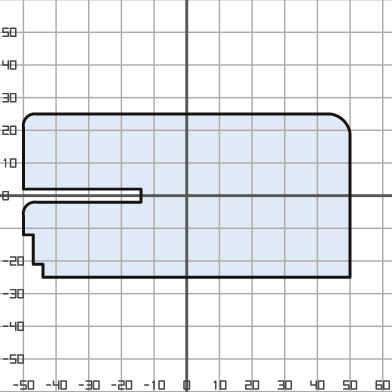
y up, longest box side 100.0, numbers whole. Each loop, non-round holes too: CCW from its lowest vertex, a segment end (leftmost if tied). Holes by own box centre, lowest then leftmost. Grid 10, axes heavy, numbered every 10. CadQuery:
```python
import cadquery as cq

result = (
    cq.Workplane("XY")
    .moveTo(-44.0, -25.0)
    .lineTo(50.0, -25.0)
    .lineTo(50.0, 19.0)
    .threePointArc((48.0, 23.0), (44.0, 25.0))
    .lineTo(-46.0, 25.0)
    .threePointArc((-49.0, 24.0), (-50.0, 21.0))
    .lineTo(-50.0, 2.0)
    .lineTo(-14.0, 2.0)
    .lineTo(-14.0, -2.0)
    .lineTo(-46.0, -2.0)
    .threePointArc((-49.0, -3.0), (-50.0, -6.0))
    .lineTo(-50.0, -12.0)
    .lineTo(-47.0, -12.0)
    .lineTo(-47.0, -21.0)
    .lineTo(-44.0, -21.0)
    .close()
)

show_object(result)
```